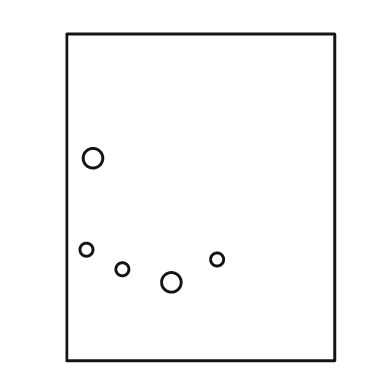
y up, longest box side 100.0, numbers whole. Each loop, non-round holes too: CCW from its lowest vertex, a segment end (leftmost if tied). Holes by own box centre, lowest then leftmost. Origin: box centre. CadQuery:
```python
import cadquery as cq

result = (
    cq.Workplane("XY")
    .moveTo(-41.0, -50.0)
    .lineTo(41.0, -50.0)
    .lineTo(41.0, 50.0)
    .lineTo(-41.0, 50.0)
    .close()
    .moveTo(-9.0, -26.0)
    .circle(3.0)
    .moveTo(-24.0, -22.0)
    .circle(2.0)
    .moveTo(5.0, -19.0)
    .circle(2.0)
    .moveTo(-35.0, -16.0)
    .circle(2.0)
    .moveTo(-33.0, 12.0)
    .circle(3.0)
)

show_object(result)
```